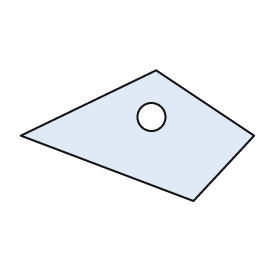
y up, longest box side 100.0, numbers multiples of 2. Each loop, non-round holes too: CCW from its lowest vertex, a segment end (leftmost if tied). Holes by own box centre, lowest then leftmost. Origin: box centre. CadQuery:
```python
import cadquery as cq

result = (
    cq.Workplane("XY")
    .moveTo(24.0, -28.0)
    .lineTo(50.0, 0.0)
    .lineTo(8.0, 28.0)
    .lineTo(-50.0, 0.0)
    .close()
    .moveTo(6.0, 8.0)
    .circle(6.0)
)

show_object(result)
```